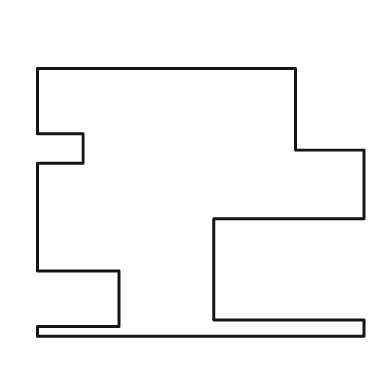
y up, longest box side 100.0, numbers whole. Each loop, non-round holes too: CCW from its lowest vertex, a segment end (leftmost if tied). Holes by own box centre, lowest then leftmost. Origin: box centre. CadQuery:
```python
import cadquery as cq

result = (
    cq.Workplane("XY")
    .moveTo(-50.0, -41.0)
    .lineTo(50.0, -41.0)
    .lineTo(50.0, -36.0)
    .lineTo(4.0, -36.0)
    .lineTo(4.0, -5.0)
    .lineTo(50.0, -5.0)
    .lineTo(50.0, 16.0)
    .lineTo(29.0, 16.0)
    .lineTo(29.0, 41.0)
    .lineTo(-50.0, 41.0)
    .lineTo(-50.0, 21.0)
    .lineTo(-36.0, 21.0)
    .lineTo(-36.0, 12.0)
    .lineTo(-50.0, 12.0)
    .lineTo(-50.0, -21.0)
    .lineTo(-25.0, -21.0)
    .lineTo(-25.0, -38.0)
    .lineTo(-50.0, -38.0)
    .close()
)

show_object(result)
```